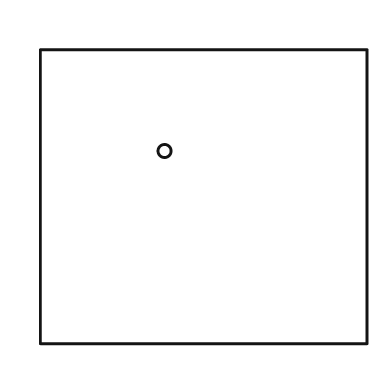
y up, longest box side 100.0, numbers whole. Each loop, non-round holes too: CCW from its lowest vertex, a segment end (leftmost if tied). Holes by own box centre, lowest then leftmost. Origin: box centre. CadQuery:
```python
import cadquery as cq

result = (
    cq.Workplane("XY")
    .moveTo(-50.0, -45.0)
    .lineTo(50.0, -45.0)
    .lineTo(50.0, 45.0)
    .lineTo(-50.0, 45.0)
    .close()
    .moveTo(-12.0, 14.0)
    .circle(2.0)
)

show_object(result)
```